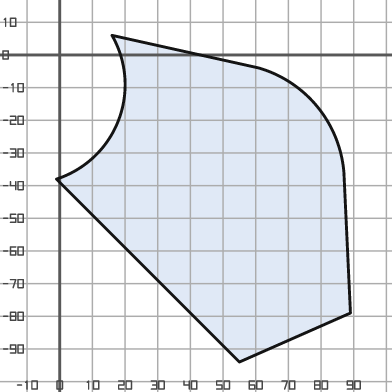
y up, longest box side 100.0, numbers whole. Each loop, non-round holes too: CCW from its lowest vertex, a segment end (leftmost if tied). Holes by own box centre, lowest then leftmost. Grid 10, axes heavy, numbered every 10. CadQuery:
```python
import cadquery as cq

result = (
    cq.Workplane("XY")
    .moveTo(55.0, -94.0)
    .lineTo(89.0, -79.0)
    .lineTo(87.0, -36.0)
    .threePointArc((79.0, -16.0), (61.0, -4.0))
    .lineTo(16.0, 6.0)
    .threePointArc((18.0, -20.0), (-1.0, -38.0))
    .close()
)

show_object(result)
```